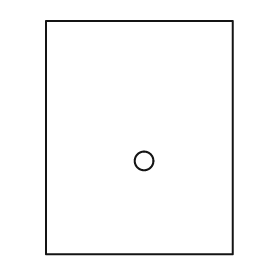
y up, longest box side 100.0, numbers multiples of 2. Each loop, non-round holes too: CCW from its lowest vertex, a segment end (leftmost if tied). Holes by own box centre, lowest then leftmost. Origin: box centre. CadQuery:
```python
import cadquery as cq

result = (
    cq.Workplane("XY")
    .moveTo(-40.0, -50.0)
    .lineTo(40.0, -50.0)
    .lineTo(40.0, 50.0)
    .lineTo(-40.0, 50.0)
    .close()
    .moveTo(2.0, -10.0)
    .circle(4.0)
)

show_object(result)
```